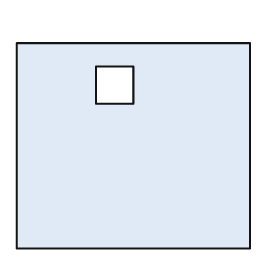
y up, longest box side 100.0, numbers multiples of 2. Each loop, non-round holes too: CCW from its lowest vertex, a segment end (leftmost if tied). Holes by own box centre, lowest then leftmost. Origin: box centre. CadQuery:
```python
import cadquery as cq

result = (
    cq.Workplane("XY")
    .moveTo(-50.0, -44.0)
    .lineTo(50.0, -44.0)
    .lineTo(50.0, 44.0)
    .lineTo(-50.0, 44.0)
    .close()
    .moveTo(-16.0, 18.0)
    .lineTo(0.0, 18.0)
    .lineTo(0.0, 34.0)
    .lineTo(-16.0, 34.0)
    .close()
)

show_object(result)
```